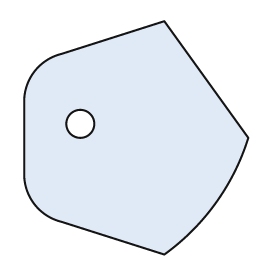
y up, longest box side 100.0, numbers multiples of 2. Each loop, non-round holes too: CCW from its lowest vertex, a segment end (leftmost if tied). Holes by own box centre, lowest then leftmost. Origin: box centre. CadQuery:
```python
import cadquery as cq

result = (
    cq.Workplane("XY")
    .moveTo(12.0, -50.0)
    .threePointArc((34.0, -28.0), (48.0, 0.0))
    .lineTo(12.0, 50.0)
    .lineTo(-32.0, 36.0)
    .threePointArc((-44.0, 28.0), (-48.0, 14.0))
    .lineTo(-48.0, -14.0)
    .threePointArc((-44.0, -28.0), (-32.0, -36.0))
    .close()
    .moveTo(-24.0, 6.0)
    .circle(6.0)
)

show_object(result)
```